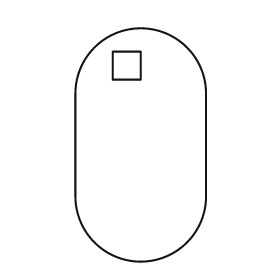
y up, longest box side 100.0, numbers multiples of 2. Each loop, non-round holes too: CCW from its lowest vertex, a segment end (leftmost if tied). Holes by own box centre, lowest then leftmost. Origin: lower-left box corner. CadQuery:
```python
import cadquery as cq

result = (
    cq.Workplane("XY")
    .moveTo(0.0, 28.0)
    .threePointArc((28.0, 0.0), (56.0, 28.0))
    .lineTo(56.0, 72.0)
    .threePointArc((28.0, 100.0), (0.0, 72.0))
    .close()
    .moveTo(16.0, 78.0)
    .lineTo(28.0, 78.0)
    .lineTo(28.0, 90.0)
    .lineTo(16.0, 90.0)
    .close()
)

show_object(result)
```